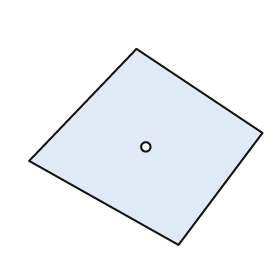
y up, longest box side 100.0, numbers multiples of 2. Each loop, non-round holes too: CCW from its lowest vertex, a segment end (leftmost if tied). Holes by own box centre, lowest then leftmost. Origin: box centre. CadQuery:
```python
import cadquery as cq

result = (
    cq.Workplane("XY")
    .moveTo(14.0, -42.0)
    .lineTo(50.0, 6.0)
    .lineTo(-4.0, 42.0)
    .lineTo(-50.0, -6.0)
    .close()
    .moveTo(0.0, 0.0)
    .circle(2.0)
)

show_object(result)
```